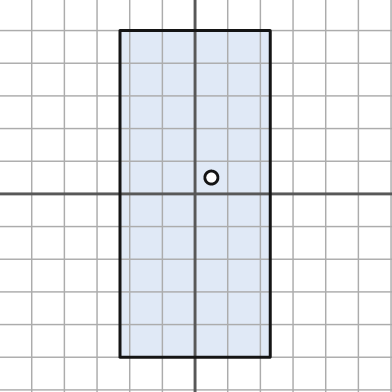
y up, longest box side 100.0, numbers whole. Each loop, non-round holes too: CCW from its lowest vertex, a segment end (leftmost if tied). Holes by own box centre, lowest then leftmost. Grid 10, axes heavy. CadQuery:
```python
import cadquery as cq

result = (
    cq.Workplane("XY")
    .moveTo(-23.0, -50.0)
    .lineTo(23.0, -50.0)
    .lineTo(23.0, 50.0)
    .lineTo(-23.0, 50.0)
    .close()
    .moveTo(5.0, 5.0)
    .circle(2.0)
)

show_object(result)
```